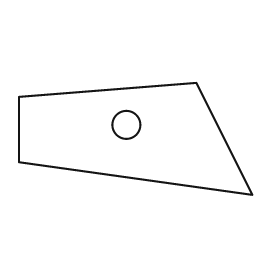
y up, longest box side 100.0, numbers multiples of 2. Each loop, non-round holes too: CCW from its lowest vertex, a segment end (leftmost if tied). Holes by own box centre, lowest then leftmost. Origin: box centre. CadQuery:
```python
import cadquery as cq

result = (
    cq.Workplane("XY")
    .moveTo(50.0, -24.0)
    .lineTo(26.0, 24.0)
    .lineTo(-50.0, 18.0)
    .lineTo(-50.0, -10.0)
    .close()
    .moveTo(-4.0, 6.0)
    .circle(6.0)
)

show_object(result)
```